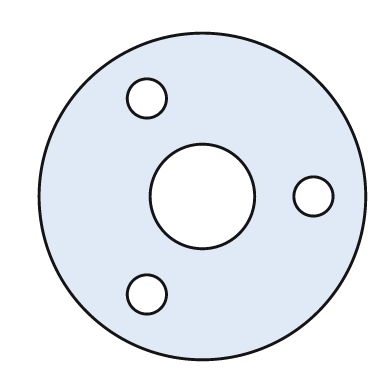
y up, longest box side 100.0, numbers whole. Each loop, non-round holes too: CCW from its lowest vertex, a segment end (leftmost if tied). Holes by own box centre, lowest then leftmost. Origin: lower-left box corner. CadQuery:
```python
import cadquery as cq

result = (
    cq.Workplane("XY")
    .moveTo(50.0, 50.0)
    .circle(50.0)
    .moveTo(33.0, 20.0)
    .circle(6.0)
    .moveTo(50.0, 50.0)
    .circle(16.0)
    .moveTo(84.0, 50.0)
    .circle(6.0)
    .moveTo(33.0, 80.0)
    .circle(6.0)
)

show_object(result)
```